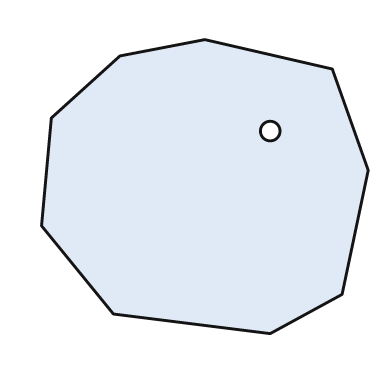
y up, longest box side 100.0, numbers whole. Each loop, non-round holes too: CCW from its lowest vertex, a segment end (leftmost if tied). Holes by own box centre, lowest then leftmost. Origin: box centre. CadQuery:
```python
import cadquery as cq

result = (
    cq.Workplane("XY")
    .moveTo(20.0, -45.0)
    .lineTo(42.0, -33.0)
    .lineTo(50.0, 5.0)
    .lineTo(39.0, 36.0)
    .lineTo(0.0, 45.0)
    .lineTo(-26.0, 40.0)
    .lineTo(-47.0, 21.0)
    .lineTo(-50.0, -12.0)
    .lineTo(-28.0, -39.0)
    .close()
    .moveTo(20.0, 17.0)
    .circle(3.0)
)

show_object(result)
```